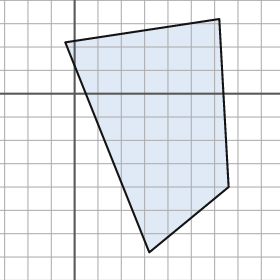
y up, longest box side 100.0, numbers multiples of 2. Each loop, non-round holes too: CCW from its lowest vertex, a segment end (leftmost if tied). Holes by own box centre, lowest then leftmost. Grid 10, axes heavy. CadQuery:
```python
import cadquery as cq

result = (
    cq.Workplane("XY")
    .moveTo(32.0, -68.0)
    .lineTo(66.0, -40.0)
    .lineTo(62.0, 32.0)
    .lineTo(-4.0, 22.0)
    .close()
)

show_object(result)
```